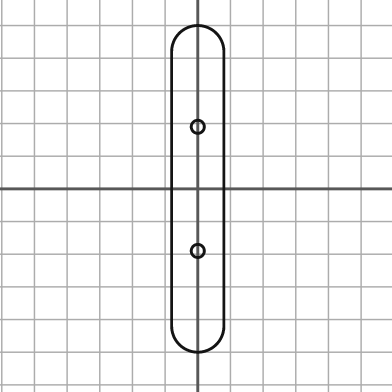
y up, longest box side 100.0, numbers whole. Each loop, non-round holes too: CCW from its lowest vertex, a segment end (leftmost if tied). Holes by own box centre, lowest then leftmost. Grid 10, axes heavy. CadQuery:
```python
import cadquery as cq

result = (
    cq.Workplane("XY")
    .moveTo(-8.0, -42.0)
    .threePointArc((0.0, -50.0), (8.0, -42.0))
    .lineTo(8.0, 42.0)
    .threePointArc((0.0, 50.0), (-8.0, 42.0))
    .close()
    .moveTo(0.0, -19.0)
    .circle(2.0)
    .moveTo(0.0, 19.0)
    .circle(2.0)
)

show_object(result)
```